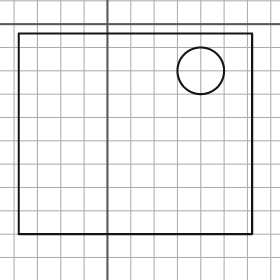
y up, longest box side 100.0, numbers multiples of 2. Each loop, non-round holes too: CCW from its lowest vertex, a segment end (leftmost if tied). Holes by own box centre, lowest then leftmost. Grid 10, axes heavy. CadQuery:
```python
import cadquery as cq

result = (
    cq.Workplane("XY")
    .moveTo(-38.0, -90.0)
    .lineTo(62.0, -90.0)
    .lineTo(62.0, -4.0)
    .lineTo(-38.0, -4.0)
    .close()
    .moveTo(40.0, -20.0)
    .circle(10.0)
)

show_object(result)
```